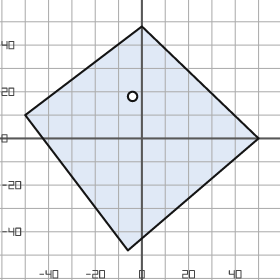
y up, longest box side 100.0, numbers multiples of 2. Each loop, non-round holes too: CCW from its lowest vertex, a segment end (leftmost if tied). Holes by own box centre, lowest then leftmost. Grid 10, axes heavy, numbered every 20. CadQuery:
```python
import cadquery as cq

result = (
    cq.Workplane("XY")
    .moveTo(-6.0, -48.0)
    .lineTo(50.0, 0.0)
    .lineTo(0.0, 48.0)
    .lineTo(-50.0, 10.0)
    .close()
    .moveTo(-4.0, 18.0)
    .circle(2.0)
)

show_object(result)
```